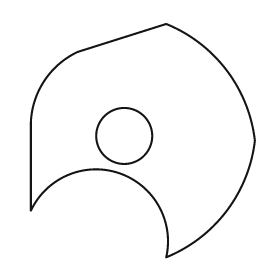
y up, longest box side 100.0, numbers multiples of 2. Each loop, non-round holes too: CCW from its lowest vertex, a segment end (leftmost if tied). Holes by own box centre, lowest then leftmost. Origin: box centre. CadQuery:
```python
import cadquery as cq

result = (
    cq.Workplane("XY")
    .moveTo(10.0, -50.0)
    .threePointArc((36.0, -30.0), (48.0, 0.0))
    .threePointArc((36.0, 30.0), (10.0, 50.0))
    .lineTo(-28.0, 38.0)
    .threePointArc((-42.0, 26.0), (-48.0, 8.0))
    .lineTo(-48.0, -30.0)
    .threePointArc((-10.0, -14.0), (10.0, -50.0))
    .close()
    .moveTo(-8.0, 2.0)
    .circle(12.0)
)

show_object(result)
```